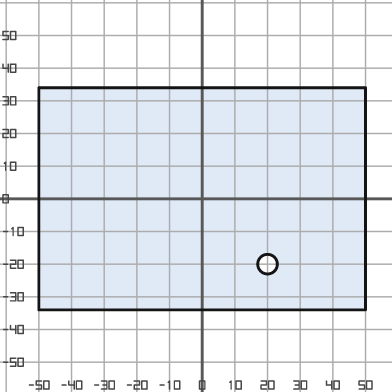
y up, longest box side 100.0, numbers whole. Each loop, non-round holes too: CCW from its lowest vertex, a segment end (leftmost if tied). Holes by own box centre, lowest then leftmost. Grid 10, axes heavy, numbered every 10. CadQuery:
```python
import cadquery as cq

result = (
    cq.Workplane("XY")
    .moveTo(-50.0, -34.0)
    .lineTo(50.0, -34.0)
    .lineTo(50.0, 34.0)
    .lineTo(-50.0, 34.0)
    .close()
    .moveTo(20.0, -20.0)
    .circle(3.0)
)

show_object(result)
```